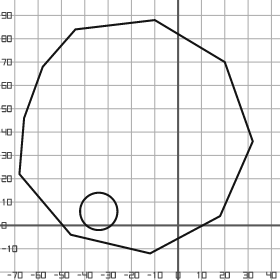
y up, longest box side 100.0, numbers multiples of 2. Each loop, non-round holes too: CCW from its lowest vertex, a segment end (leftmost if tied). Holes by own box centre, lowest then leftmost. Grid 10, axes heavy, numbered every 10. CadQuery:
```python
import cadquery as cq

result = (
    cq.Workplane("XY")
    .moveTo(-12.0, -12.0)
    .lineTo(18.0, 4.0)
    .lineTo(32.0, 36.0)
    .lineTo(20.0, 70.0)
    .lineTo(-10.0, 88.0)
    .lineTo(-44.0, 84.0)
    .lineTo(-58.0, 68.0)
    .lineTo(-66.0, 46.0)
    .lineTo(-68.0, 22.0)
    .lineTo(-46.0, -4.0)
    .close()
    .moveTo(-34.0, 6.0)
    .circle(8.0)
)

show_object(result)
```